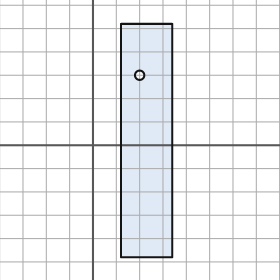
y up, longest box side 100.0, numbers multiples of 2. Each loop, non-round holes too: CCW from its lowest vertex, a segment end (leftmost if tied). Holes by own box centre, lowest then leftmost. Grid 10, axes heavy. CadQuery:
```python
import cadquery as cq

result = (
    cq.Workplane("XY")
    .moveTo(12.0, -48.0)
    .lineTo(34.0, -48.0)
    .lineTo(34.0, 52.0)
    .lineTo(12.0, 52.0)
    .close()
    .moveTo(20.0, 30.0)
    .circle(2.0)
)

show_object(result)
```